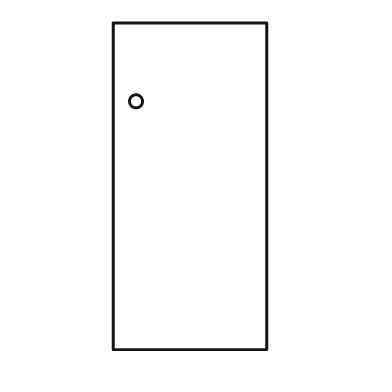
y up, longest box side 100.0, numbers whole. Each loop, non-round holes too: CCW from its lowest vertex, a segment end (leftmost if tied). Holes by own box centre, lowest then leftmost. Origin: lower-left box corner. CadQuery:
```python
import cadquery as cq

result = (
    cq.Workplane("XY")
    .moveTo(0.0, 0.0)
    .lineTo(47.0, 0.0)
    .lineTo(47.0, 100.0)
    .lineTo(0.0, 100.0)
    .close()
    .moveTo(7.0, 76.0)
    .circle(2.0)
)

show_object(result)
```